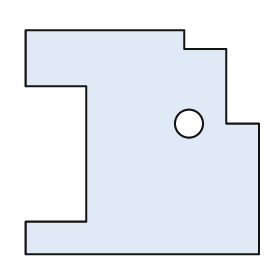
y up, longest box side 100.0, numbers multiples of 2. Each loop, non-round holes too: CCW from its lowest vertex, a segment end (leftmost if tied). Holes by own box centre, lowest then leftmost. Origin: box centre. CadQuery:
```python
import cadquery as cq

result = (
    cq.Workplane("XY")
    .moveTo(-50.0, -48.0)
    .lineTo(50.0, -48.0)
    .lineTo(50.0, 8.0)
    .lineTo(36.0, 8.0)
    .lineTo(36.0, 40.0)
    .lineTo(18.0, 40.0)
    .lineTo(18.0, 48.0)
    .lineTo(-50.0, 48.0)
    .lineTo(-50.0, 24.0)
    .lineTo(-24.0, 24.0)
    .lineTo(-24.0, -34.0)
    .lineTo(-50.0, -34.0)
    .close()
    .moveTo(20.0, 8.0)
    .circle(6.0)
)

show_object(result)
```